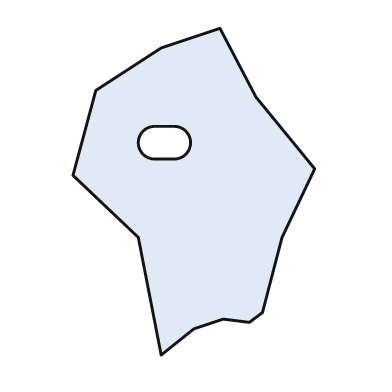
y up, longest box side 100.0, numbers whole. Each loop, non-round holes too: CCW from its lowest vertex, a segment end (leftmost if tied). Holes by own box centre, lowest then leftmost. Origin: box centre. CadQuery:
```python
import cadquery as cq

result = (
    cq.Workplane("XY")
    .moveTo(-10.0, -50.0)
    .lineTo(0.0, -42.0)
    .lineTo(9.0, -39.0)
    .lineTo(17.0, -40.0)
    .lineTo(21.0, -37.0)
    .lineTo(27.0, -14.0)
    .lineTo(37.0, 7.0)
    .lineTo(19.0, 29.0)
    .lineTo(8.0, 50.0)
    .lineTo(-10.0, 44.0)
    .lineTo(-30.0, 31.0)
    .lineTo(-37.0, 5.0)
    .lineTo(-17.0, -14.0)
    .close()
    .moveTo(-12.0, 10.0)
    .lineTo(-6.0, 10.0)
    .threePointArc((-1.0, 15.0), (-6.0, 20.0))
    .lineTo(-12.0, 20.0)
    .threePointArc((-17.0, 15.0), (-12.0, 10.0))
    .close()
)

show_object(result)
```